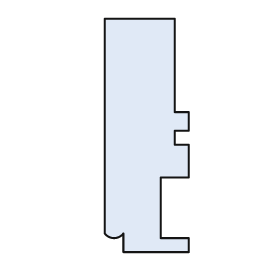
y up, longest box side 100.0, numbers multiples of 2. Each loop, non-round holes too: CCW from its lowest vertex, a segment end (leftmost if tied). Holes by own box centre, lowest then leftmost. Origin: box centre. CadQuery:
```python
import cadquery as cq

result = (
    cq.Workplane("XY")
    .moveTo(-10.0, -50.0)
    .lineTo(18.0, -50.0)
    .lineTo(18.0, -44.0)
    .lineTo(6.0, -44.0)
    .lineTo(6.0, -18.0)
    .lineTo(18.0, -18.0)
    .lineTo(18.0, -4.0)
    .lineTo(12.0, -4.0)
    .lineTo(12.0, 2.0)
    .lineTo(18.0, 2.0)
    .lineTo(18.0, 10.0)
    .lineTo(12.0, 10.0)
    .lineTo(12.0, 50.0)
    .lineTo(-18.0, 50.0)
    .lineTo(-18.0, -42.0)
    .threePointArc((-14.0, -44.0), (-10.0, -42.0))
    .close()
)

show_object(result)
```